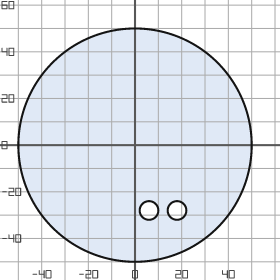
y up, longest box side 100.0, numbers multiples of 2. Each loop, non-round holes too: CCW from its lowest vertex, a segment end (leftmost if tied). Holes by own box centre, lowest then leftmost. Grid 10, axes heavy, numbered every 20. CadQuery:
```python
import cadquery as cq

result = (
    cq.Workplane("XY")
    .moveTo(0.0, 0.0)
    .circle(50.0)
    .moveTo(6.0, -28.0)
    .circle(4.0)
    .moveTo(18.0, -28.0)
    .circle(4.0)
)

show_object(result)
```